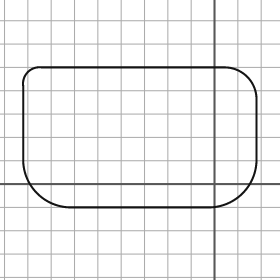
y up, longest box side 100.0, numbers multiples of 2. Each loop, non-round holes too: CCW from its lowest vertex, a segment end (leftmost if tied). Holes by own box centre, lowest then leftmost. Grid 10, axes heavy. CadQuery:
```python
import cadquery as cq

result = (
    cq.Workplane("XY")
    .moveTo(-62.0, -10.0)
    .lineTo(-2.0, -10.0)
    .threePointArc((12.0, -4.0), (18.0, 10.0))
    .lineTo(18.0, 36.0)
    .threePointArc((14.0, 46.0), (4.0, 50.0))
    .lineTo(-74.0, 50.0)
    .threePointArc((-80.0, 48.0), (-82.0, 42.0))
    .lineTo(-82.0, 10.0)
    .threePointArc((-76.0, -4.0), (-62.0, -10.0))
    .close()
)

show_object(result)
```